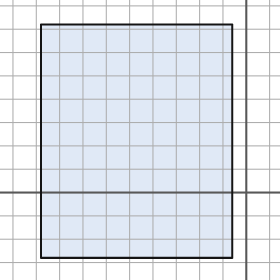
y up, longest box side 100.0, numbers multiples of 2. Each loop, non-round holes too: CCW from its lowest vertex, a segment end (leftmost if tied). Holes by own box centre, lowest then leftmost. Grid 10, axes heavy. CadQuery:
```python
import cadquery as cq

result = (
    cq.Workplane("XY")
    .moveTo(-88.0, -28.0)
    .lineTo(-6.0, -28.0)
    .lineTo(-6.0, 72.0)
    .lineTo(-88.0, 72.0)
    .close()
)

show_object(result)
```